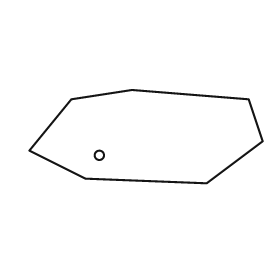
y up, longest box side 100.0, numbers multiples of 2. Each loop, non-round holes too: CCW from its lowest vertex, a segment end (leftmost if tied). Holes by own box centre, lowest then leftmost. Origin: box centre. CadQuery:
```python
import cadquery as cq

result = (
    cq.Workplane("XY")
    .moveTo(26.0, -20.0)
    .lineTo(50.0, -2.0)
    .lineTo(44.0, 16.0)
    .lineTo(-6.0, 20.0)
    .lineTo(-32.0, 16.0)
    .lineTo(-50.0, -6.0)
    .lineTo(-26.0, -18.0)
    .close()
    .moveTo(-20.0, -8.0)
    .circle(2.0)
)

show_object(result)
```